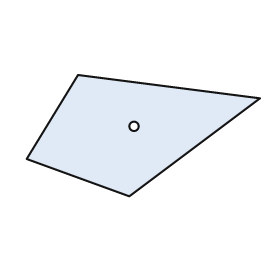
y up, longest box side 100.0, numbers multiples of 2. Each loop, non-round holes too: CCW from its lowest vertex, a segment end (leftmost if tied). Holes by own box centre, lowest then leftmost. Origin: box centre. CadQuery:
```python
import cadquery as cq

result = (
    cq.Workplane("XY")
    .moveTo(-6.0, -26.0)
    .lineTo(50.0, 16.0)
    .lineTo(-28.0, 26.0)
    .lineTo(-50.0, -10.0)
    .close()
    .moveTo(-4.0, 4.0)
    .circle(2.0)
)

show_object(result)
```